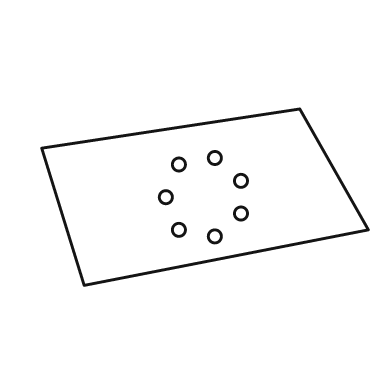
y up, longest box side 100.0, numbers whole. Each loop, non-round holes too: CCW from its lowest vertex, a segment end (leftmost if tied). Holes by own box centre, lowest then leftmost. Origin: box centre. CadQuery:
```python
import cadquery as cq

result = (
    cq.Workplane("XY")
    .moveTo(-37.0, -27.0)
    .lineTo(50.0, -10.0)
    .lineTo(29.0, 27.0)
    .lineTo(-50.0, 15.0)
    .close()
    .moveTo(3.0, -12.0)
    .circle(2.0)
    .moveTo(-8.0, -10.0)
    .circle(2.0)
    .moveTo(11.0, -5.0)
    .circle(2.0)
    .moveTo(-12.0, 0.0)
    .circle(2.0)
    .moveTo(11.0, 5.0)
    .circle(2.0)
    .moveTo(-8.0, 10.0)
    .circle(2.0)
    .moveTo(3.0, 12.0)
    .circle(2.0)
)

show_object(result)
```